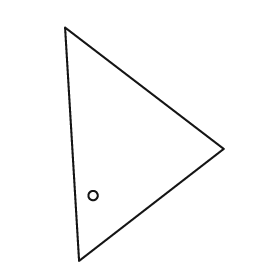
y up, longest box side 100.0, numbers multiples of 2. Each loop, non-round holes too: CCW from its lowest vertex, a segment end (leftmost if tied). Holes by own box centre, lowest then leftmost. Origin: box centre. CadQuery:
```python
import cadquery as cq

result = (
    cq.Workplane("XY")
    .moveTo(-28.0, -50.0)
    .lineTo(34.0, -2.0)
    .lineTo(-34.0, 50.0)
    .close()
    .moveTo(-22.0, -22.0)
    .circle(2.0)
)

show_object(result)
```